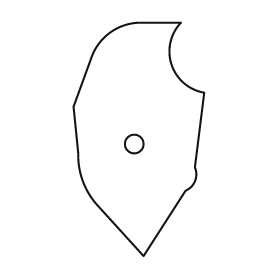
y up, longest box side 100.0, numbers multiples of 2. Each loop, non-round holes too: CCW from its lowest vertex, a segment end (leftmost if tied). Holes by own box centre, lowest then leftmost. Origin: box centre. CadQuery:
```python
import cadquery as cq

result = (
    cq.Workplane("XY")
    .moveTo(2.0, -50.0)
    .lineTo(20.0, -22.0)
    .threePointArc((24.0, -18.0), (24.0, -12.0))
    .lineTo(28.0, 20.0)
    .threePointArc((14.0, 32.0), (18.0, 50.0))
    .lineTo(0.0, 50.0)
    .threePointArc((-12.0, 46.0), (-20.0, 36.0))
    .lineTo(-28.0, 14.0)
    .lineTo(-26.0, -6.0)
    .threePointArc((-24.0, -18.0), (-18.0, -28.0))
    .close()
    .moveTo(-2.0, -2.0)
    .circle(4.0)
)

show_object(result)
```